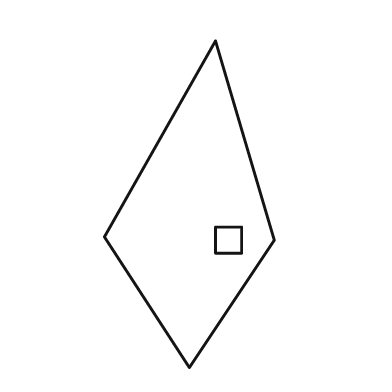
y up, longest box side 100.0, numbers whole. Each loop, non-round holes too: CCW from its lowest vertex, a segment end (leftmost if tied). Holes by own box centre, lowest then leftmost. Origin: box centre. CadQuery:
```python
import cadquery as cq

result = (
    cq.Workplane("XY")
    .moveTo(0.0, -50.0)
    .lineTo(26.0, -11.0)
    .lineTo(8.0, 50.0)
    .lineTo(-26.0, -10.0)
    .close()
    .moveTo(8.0, -15.0)
    .lineTo(16.0, -15.0)
    .lineTo(16.0, -7.0)
    .lineTo(8.0, -7.0)
    .close()
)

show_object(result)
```